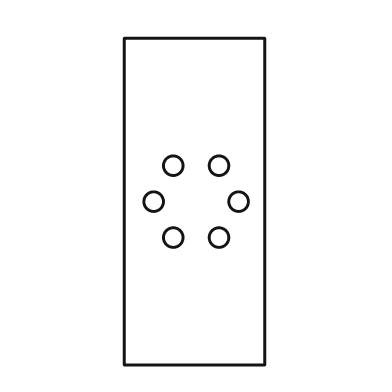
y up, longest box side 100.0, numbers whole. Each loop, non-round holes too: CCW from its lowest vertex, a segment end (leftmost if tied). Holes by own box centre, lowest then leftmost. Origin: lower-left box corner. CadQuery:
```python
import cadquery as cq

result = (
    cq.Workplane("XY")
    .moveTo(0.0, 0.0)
    .lineTo(43.0, 0.0)
    .lineTo(43.0, 100.0)
    .lineTo(0.0, 100.0)
    .close()
    .moveTo(15.0, 39.0)
    .circle(3.0)
    .moveTo(29.0, 39.0)
    .circle(3.0)
    .moveTo(9.0, 50.0)
    .circle(3.0)
    .moveTo(35.0, 50.0)
    .circle(3.0)
    .moveTo(15.0, 61.0)
    .circle(3.0)
    .moveTo(29.0, 61.0)
    .circle(3.0)
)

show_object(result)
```